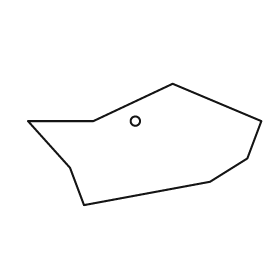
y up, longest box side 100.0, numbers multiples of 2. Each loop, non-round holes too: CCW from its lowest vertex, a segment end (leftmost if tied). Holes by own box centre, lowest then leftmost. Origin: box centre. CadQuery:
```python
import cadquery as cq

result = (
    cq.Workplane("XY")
    .moveTo(-26.0, -26.0)
    .lineTo(28.0, -16.0)
    .lineTo(44.0, -6.0)
    .lineTo(50.0, 10.0)
    .lineTo(12.0, 26.0)
    .lineTo(-22.0, 10.0)
    .lineTo(-50.0, 10.0)
    .lineTo(-32.0, -10.0)
    .close()
    .moveTo(-4.0, 10.0)
    .circle(2.0)
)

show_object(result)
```